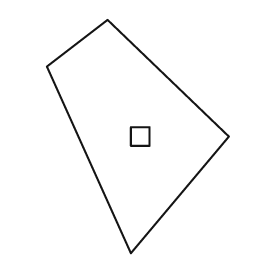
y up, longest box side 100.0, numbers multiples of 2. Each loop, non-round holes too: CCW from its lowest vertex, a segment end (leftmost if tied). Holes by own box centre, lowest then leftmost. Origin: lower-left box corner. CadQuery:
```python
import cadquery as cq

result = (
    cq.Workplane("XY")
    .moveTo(36.0, 0.0)
    .lineTo(78.0, 50.0)
    .lineTo(26.0, 100.0)
    .lineTo(0.0, 80.0)
    .close()
    .moveTo(36.0, 46.0)
    .lineTo(44.0, 46.0)
    .lineTo(44.0, 54.0)
    .lineTo(36.0, 54.0)
    .close()
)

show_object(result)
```